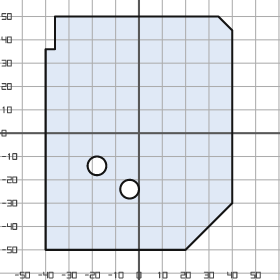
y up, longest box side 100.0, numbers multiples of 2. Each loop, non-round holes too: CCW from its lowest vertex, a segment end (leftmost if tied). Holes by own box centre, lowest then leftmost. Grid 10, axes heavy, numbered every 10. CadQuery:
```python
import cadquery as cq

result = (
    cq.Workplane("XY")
    .moveTo(-40.0, -50.0)
    .lineTo(20.0, -50.0)
    .lineTo(40.0, -30.0)
    .lineTo(40.0, 44.0)
    .lineTo(34.0, 50.0)
    .lineTo(-36.0, 50.0)
    .lineTo(-36.0, 36.0)
    .lineTo(-40.0, 36.0)
    .close()
    .moveTo(-4.0, -24.0)
    .circle(4.0)
    .moveTo(-18.0, -14.0)
    .circle(4.0)
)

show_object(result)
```